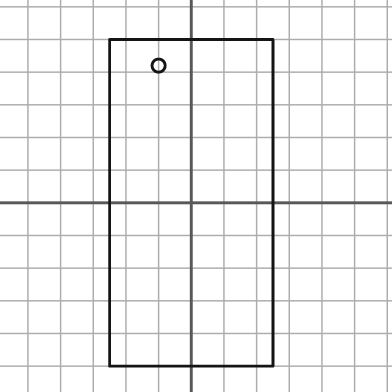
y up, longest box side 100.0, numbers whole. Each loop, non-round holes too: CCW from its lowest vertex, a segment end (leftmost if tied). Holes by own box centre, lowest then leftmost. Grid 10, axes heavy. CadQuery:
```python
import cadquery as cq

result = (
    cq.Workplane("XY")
    .moveTo(-25.0, -50.0)
    .lineTo(25.0, -50.0)
    .lineTo(25.0, 50.0)
    .lineTo(-25.0, 50.0)
    .close()
    .moveTo(-10.0, 42.0)
    .circle(2.0)
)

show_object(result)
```